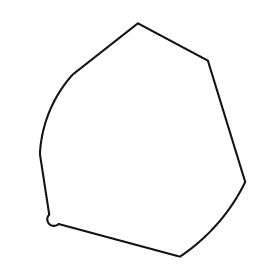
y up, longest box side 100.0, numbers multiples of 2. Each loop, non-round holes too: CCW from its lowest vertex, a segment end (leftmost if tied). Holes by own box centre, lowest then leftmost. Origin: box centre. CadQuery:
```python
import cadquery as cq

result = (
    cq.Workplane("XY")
    .moveTo(16.0, -50.0)
    .threePointArc((32.0, -36.0), (44.0, -18.0))
    .lineTo(28.0, 34.0)
    .lineTo(-2.0, 50.0)
    .lineTo(-30.0, 28.0)
    .threePointArc((-40.0, 12.0), (-44.0, -6.0))
    .lineTo(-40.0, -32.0)
    .threePointArc((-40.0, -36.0), (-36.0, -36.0))
    .close()
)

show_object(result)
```